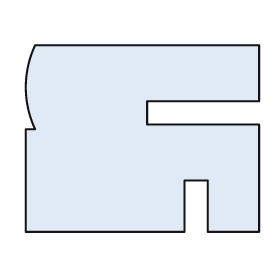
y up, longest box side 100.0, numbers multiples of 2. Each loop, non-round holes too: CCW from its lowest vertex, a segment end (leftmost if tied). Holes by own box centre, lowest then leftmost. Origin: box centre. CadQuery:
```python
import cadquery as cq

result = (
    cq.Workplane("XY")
    .moveTo(-50.0, -40.0)
    .lineTo(18.0, -40.0)
    .lineTo(18.0, -18.0)
    .lineTo(28.0, -18.0)
    .lineTo(28.0, -40.0)
    .lineTo(50.0, -40.0)
    .lineTo(50.0, 6.0)
    .lineTo(2.0, 6.0)
    .lineTo(2.0, 16.0)
    .lineTo(50.0, 16.0)
    .lineTo(50.0, 40.0)
    .lineTo(-46.0, 40.0)
    .threePointArc((-50.0, 22.0), (-46.0, 4.0))
    .lineTo(-50.0, 4.0)
    .close()
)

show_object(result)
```